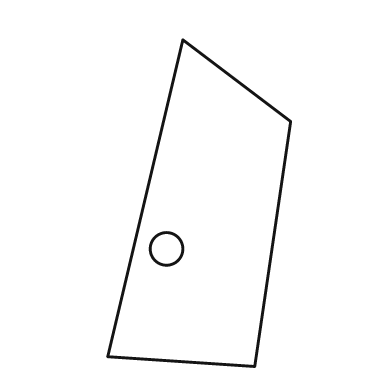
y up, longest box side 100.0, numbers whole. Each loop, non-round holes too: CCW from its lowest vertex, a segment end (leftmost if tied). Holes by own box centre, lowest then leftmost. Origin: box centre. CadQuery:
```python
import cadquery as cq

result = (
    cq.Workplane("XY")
    .moveTo(17.0, -50.0)
    .lineTo(28.0, 25.0)
    .lineTo(-5.0, 50.0)
    .lineTo(-28.0, -47.0)
    .close()
    .moveTo(-10.0, -14.0)
    .circle(5.0)
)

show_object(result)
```